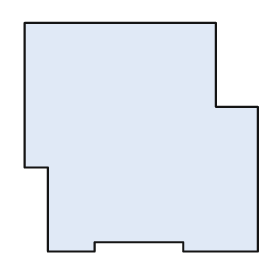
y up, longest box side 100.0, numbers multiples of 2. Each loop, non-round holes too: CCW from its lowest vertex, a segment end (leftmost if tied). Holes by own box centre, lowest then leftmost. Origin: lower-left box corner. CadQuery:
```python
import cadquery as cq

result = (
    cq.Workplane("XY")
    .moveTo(10.0, 0.0)
    .lineTo(30.0, 0.0)
    .lineTo(30.0, 4.0)
    .lineTo(68.0, 4.0)
    .lineTo(68.0, 0.0)
    .lineTo(100.0, 0.0)
    .lineTo(100.0, 62.0)
    .lineTo(82.0, 62.0)
    .lineTo(82.0, 98.0)
    .lineTo(0.0, 98.0)
    .lineTo(0.0, 36.0)
    .lineTo(10.0, 36.0)
    .close()
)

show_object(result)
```